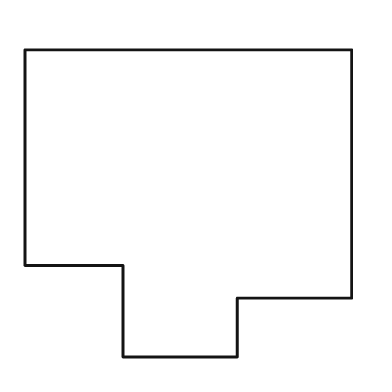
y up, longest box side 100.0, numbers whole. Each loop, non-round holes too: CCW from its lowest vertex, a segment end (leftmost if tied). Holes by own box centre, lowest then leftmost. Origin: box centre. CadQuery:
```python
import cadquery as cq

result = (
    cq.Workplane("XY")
    .moveTo(-20.0, -47.0)
    .lineTo(15.0, -47.0)
    .lineTo(15.0, -29.0)
    .lineTo(50.0, -29.0)
    .lineTo(50.0, 47.0)
    .lineTo(-50.0, 47.0)
    .lineTo(-50.0, -19.0)
    .lineTo(-20.0, -19.0)
    .close()
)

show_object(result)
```